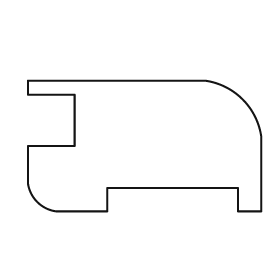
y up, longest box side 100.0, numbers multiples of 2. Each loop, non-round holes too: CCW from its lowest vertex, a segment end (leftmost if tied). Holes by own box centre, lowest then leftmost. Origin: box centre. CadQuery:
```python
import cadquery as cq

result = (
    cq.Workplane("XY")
    .moveTo(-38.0, -28.0)
    .lineTo(-16.0, -28.0)
    .lineTo(-16.0, -18.0)
    .lineTo(40.0, -18.0)
    .lineTo(40.0, -28.0)
    .lineTo(50.0, -28.0)
    .lineTo(50.0, 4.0)
    .threePointArc((42.0, 20.0), (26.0, 28.0))
    .lineTo(-50.0, 28.0)
    .lineTo(-50.0, 22.0)
    .lineTo(-30.0, 22.0)
    .lineTo(-30.0, 0.0)
    .lineTo(-50.0, 0.0)
    .lineTo(-50.0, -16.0)
    .threePointArc((-46.0, -24.0), (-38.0, -28.0))
    .close()
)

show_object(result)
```